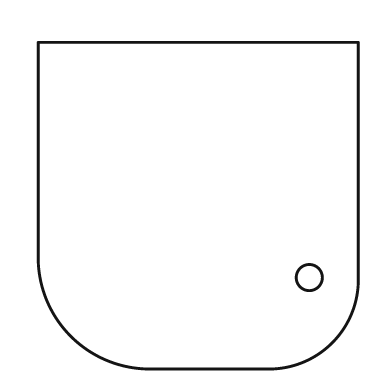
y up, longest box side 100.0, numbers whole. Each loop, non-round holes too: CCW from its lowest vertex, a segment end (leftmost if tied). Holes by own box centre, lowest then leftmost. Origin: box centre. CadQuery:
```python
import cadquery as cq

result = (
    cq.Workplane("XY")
    .moveTo(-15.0, -50.0)
    .lineTo(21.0, -50.0)
    .threePointArc((41.0, -42.0), (49.0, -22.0))
    .lineTo(49.0, 50.0)
    .lineTo(-49.0, 50.0)
    .lineTo(-49.0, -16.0)
    .threePointArc((-39.0, -40.0), (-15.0, -50.0))
    .close()
    .moveTo(34.0, -22.0)
    .circle(4.0)
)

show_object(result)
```